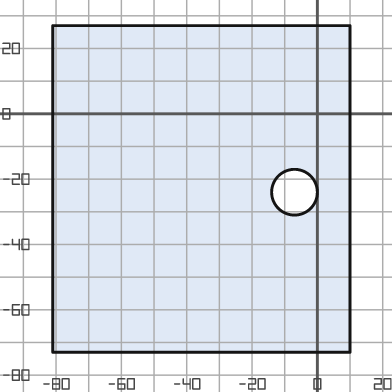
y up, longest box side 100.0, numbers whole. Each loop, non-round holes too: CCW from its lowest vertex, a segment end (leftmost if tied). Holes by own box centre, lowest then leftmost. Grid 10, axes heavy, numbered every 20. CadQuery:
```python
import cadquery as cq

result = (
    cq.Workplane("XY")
    .moveTo(-81.0, -73.0)
    .lineTo(10.0, -73.0)
    .lineTo(10.0, 27.0)
    .lineTo(-81.0, 27.0)
    .close()
    .moveTo(-7.0, -24.0)
    .circle(7.0)
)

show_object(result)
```